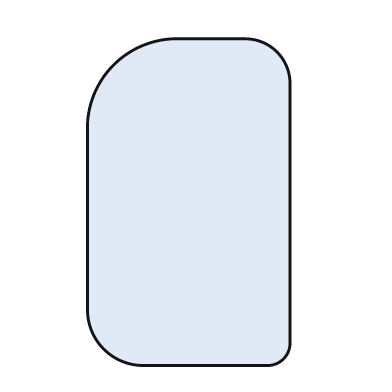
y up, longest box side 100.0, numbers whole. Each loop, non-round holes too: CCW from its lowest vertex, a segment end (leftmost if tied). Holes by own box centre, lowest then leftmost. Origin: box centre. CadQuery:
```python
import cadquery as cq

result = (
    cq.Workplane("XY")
    .moveTo(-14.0, -50.0)
    .lineTo(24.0, -50.0)
    .threePointArc((29.0, -48.0), (31.0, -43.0))
    .lineTo(31.0, 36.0)
    .threePointArc((27.0, 46.0), (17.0, 50.0))
    .lineTo(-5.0, 50.0)
    .threePointArc((-23.0, 42.0), (-31.0, 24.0))
    .lineTo(-31.0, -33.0)
    .threePointArc((-26.0, -45.0), (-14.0, -50.0))
    .close()
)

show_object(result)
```